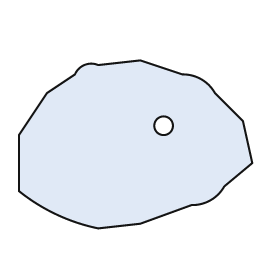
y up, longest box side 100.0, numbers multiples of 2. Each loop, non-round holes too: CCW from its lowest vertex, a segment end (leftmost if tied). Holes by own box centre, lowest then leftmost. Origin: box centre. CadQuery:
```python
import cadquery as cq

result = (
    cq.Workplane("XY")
    .moveTo(-16.0, -36.0)
    .lineTo(2.0, -34.0)
    .lineTo(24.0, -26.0)
    .threePointArc((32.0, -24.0), (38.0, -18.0))
    .lineTo(50.0, -8.0)
    .lineTo(46.0, 10.0)
    .lineTo(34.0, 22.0)
    .threePointArc((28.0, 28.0), (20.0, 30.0))
    .lineTo(2.0, 36.0)
    .lineTo(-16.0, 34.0)
    .threePointArc((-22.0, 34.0), (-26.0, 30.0))
    .lineTo(-38.0, 22.0)
    .lineTo(-50.0, 4.0)
    .lineTo(-50.0, -20.0)
    .threePointArc((-34.0, -30.0), (-16.0, -36.0))
    .close()
    .moveTo(12.0, 8.0)
    .circle(4.0)
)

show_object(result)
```